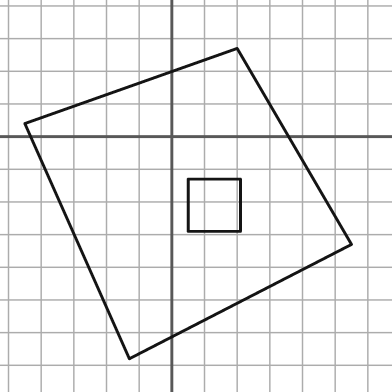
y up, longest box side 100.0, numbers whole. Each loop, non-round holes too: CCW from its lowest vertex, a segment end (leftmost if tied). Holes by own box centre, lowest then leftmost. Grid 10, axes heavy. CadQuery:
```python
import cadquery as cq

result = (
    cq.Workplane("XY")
    .moveTo(-13.0, -68.0)
    .lineTo(55.0, -33.0)
    .lineTo(20.0, 27.0)
    .lineTo(-45.0, 4.0)
    .close()
    .moveTo(5.0, -29.0)
    .lineTo(21.0, -29.0)
    .lineTo(21.0, -13.0)
    .lineTo(5.0, -13.0)
    .close()
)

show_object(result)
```